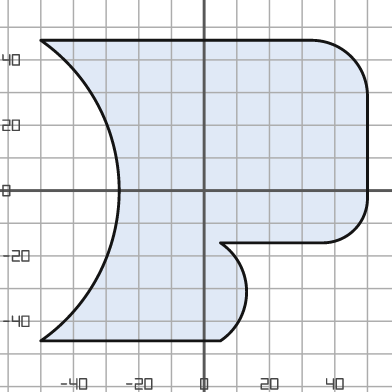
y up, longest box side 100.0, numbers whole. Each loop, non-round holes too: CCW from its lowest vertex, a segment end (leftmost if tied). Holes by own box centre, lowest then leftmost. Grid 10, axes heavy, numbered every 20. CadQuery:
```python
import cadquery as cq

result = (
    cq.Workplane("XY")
    .moveTo(-50.0, -46.0)
    .lineTo(5.0, -46.0)
    .threePointArc((13.0, -31.0), (5.0, -16.0))
    .lineTo(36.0, -16.0)
    .threePointArc((46.0, -12.0), (50.0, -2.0))
    .lineTo(50.0, 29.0)
    .threePointArc((45.0, 41.0), (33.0, 46.0))
    .lineTo(-50.0, 46.0)
    .threePointArc((-26.0, 0.0), (-50.0, -46.0))
    .close()
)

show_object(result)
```